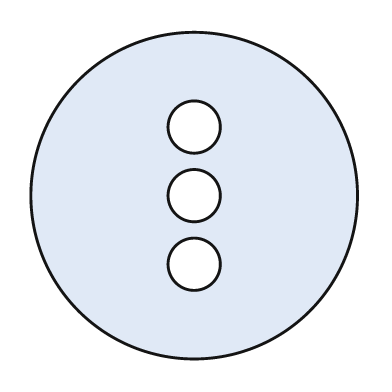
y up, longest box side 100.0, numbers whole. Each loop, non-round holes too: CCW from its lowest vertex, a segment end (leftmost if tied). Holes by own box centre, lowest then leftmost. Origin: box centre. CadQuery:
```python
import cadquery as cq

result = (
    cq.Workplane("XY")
    .moveTo(0.0, 0.0)
    .circle(50.0)
    .moveTo(0.0, -21.0)
    .circle(8.0)
    .moveTo(0.0, 0.0)
    .circle(8.0)
    .moveTo(0.0, 21.0)
    .circle(8.0)
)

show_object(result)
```